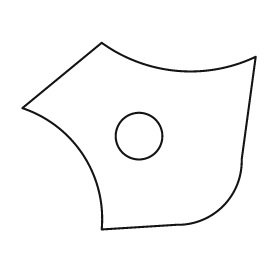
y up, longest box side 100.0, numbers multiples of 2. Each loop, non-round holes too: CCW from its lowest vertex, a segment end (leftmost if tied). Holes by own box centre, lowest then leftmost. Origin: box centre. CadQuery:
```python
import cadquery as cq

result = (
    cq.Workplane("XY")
    .moveTo(-16.0, -40.0)
    .lineTo(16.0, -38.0)
    .threePointArc((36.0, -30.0), (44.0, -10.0))
    .lineTo(50.0, 34.0)
    .threePointArc((16.0, 28.0), (-16.0, 40.0))
    .lineTo(-50.0, 12.0)
    .threePointArc((-24.0, -8.0), (-16.0, -40.0))
    .close()
    .moveTo(0.0, 0.0)
    .circle(10.0)
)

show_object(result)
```